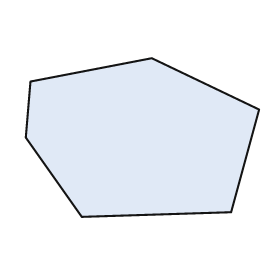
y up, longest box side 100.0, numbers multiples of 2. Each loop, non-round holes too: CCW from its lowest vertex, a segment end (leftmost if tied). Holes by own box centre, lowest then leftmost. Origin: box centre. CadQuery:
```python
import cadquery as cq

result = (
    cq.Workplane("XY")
    .moveTo(-26.0, -34.0)
    .lineTo(38.0, -32.0)
    .lineTo(50.0, 12.0)
    .lineTo(4.0, 34.0)
    .lineTo(-48.0, 24.0)
    .lineTo(-50.0, 0.0)
    .close()
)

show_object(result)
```